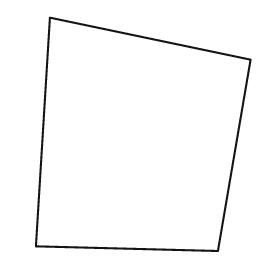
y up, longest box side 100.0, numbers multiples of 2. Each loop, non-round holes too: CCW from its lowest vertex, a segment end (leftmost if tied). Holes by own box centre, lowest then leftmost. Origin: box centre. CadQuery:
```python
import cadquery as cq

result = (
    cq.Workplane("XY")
    .moveTo(32.0, -50.0)
    .lineTo(46.0, 32.0)
    .lineTo(-40.0, 50.0)
    .lineTo(-46.0, -48.0)
    .close()
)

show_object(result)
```